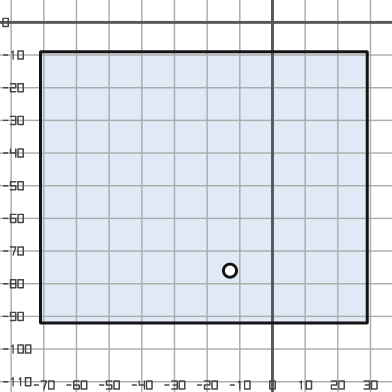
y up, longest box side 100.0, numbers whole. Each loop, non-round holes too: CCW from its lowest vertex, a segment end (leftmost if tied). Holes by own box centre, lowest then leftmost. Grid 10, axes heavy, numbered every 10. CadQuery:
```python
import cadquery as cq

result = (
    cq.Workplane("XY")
    .moveTo(-71.0, -92.0)
    .lineTo(29.0, -92.0)
    .lineTo(29.0, -9.0)
    .lineTo(-71.0, -9.0)
    .close()
    .moveTo(-13.0, -76.0)
    .circle(2.0)
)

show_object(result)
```